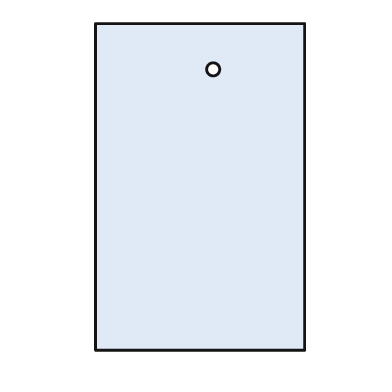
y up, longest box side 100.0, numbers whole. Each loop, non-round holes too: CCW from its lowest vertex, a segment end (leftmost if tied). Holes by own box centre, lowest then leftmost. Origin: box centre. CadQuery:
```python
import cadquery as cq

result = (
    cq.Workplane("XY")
    .moveTo(-32.0, -50.0)
    .lineTo(32.0, -50.0)
    .lineTo(32.0, 50.0)
    .lineTo(-32.0, 50.0)
    .close()
    .moveTo(4.0, 36.0)
    .circle(2.0)
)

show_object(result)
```